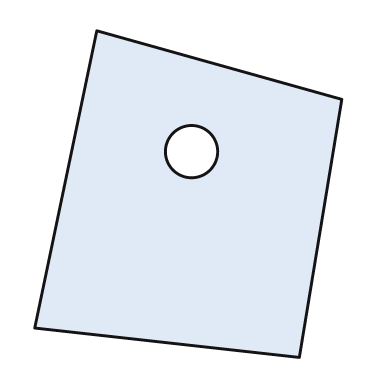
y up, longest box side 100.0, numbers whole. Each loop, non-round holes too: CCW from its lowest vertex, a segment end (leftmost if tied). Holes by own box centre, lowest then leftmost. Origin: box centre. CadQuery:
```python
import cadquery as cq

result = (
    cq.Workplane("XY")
    .moveTo(34.0, -50.0)
    .lineTo(47.0, 29.0)
    .lineTo(-28.0, 50.0)
    .lineTo(-47.0, -41.0)
    .close()
    .moveTo(1.0, 13.0)
    .circle(8.0)
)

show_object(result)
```